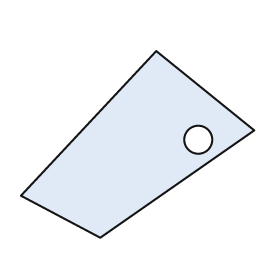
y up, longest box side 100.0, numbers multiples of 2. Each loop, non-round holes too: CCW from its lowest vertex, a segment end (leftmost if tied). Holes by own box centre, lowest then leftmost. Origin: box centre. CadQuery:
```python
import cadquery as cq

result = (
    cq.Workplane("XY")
    .moveTo(-16.0, -40.0)
    .lineTo(50.0, 6.0)
    .lineTo(8.0, 40.0)
    .lineTo(-50.0, -22.0)
    .close()
    .moveTo(26.0, 2.0)
    .circle(6.0)
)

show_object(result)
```